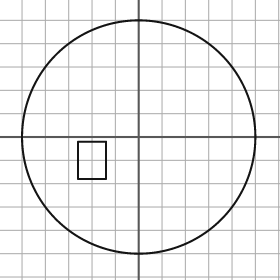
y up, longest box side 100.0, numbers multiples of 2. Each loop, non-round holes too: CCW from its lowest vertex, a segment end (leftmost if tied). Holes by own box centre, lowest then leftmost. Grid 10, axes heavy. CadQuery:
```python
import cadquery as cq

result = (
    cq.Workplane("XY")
    .moveTo(0.0, 0.0)
    .circle(50.0)
    .moveTo(-26.0, -18.0)
    .lineTo(-14.0, -18.0)
    .lineTo(-14.0, -2.0)
    .lineTo(-26.0, -2.0)
    .close()
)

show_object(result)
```